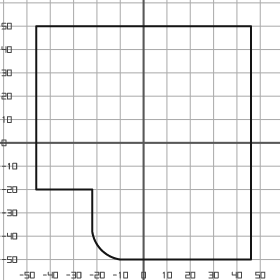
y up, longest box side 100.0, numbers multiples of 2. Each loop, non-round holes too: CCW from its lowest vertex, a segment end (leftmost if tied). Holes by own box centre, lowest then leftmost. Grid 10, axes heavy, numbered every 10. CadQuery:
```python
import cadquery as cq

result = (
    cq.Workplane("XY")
    .moveTo(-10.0, -50.0)
    .lineTo(46.0, -50.0)
    .lineTo(46.0, 50.0)
    .lineTo(-46.0, 50.0)
    .lineTo(-46.0, -20.0)
    .lineTo(-22.0, -20.0)
    .lineTo(-22.0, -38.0)
    .threePointArc((-18.0, -46.0), (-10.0, -50.0))
    .close()
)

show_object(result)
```